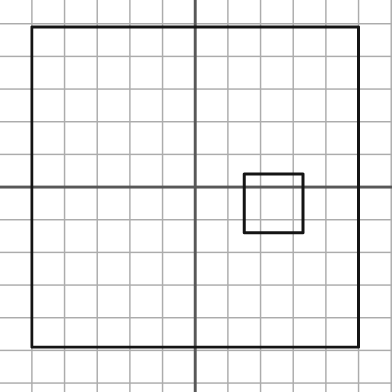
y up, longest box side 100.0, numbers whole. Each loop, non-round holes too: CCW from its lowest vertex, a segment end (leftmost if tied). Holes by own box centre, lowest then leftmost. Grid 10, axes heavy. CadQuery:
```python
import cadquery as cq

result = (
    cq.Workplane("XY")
    .moveTo(-50.0, -49.0)
    .lineTo(50.0, -49.0)
    .lineTo(50.0, 49.0)
    .lineTo(-50.0, 49.0)
    .close()
    .moveTo(15.0, -14.0)
    .lineTo(33.0, -14.0)
    .lineTo(33.0, 4.0)
    .lineTo(15.0, 4.0)
    .close()
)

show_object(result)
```